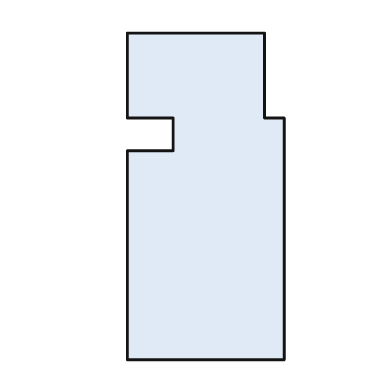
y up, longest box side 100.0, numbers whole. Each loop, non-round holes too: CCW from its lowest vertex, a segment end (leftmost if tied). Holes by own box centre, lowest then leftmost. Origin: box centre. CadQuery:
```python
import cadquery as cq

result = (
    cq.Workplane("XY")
    .moveTo(-24.0, -50.0)
    .lineTo(24.0, -50.0)
    .lineTo(24.0, 24.0)
    .lineTo(18.0, 24.0)
    .lineTo(18.0, 50.0)
    .lineTo(-24.0, 50.0)
    .lineTo(-24.0, 24.0)
    .lineTo(-10.0, 24.0)
    .lineTo(-10.0, 14.0)
    .lineTo(-24.0, 14.0)
    .close()
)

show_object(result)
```